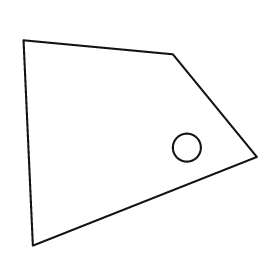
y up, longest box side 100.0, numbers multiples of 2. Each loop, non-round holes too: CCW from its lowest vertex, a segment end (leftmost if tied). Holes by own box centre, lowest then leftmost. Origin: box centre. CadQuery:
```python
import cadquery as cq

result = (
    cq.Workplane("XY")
    .moveTo(-46.0, -44.0)
    .lineTo(50.0, -6.0)
    .lineTo(14.0, 38.0)
    .lineTo(-50.0, 44.0)
    .close()
    .moveTo(20.0, -2.0)
    .circle(6.0)
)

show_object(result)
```